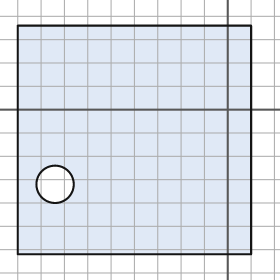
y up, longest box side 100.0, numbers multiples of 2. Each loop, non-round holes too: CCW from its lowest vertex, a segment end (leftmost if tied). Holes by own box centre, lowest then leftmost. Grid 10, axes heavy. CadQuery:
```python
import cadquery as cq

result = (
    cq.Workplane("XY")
    .moveTo(-90.0, -62.0)
    .lineTo(10.0, -62.0)
    .lineTo(10.0, 36.0)
    .lineTo(-90.0, 36.0)
    .close()
    .moveTo(-74.0, -32.0)
    .circle(8.0)
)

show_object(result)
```